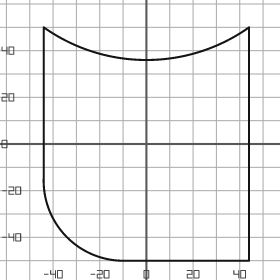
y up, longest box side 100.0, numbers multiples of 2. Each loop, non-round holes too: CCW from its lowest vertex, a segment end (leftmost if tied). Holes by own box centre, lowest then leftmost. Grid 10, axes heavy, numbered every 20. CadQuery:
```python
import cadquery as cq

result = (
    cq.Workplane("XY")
    .moveTo(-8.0, -50.0)
    .lineTo(44.0, -50.0)
    .lineTo(44.0, 50.0)
    .threePointArc((0.0, 36.0), (-44.0, 50.0))
    .lineTo(-44.0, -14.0)
    .threePointArc((-34.0, -40.0), (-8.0, -50.0))
    .close()
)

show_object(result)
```